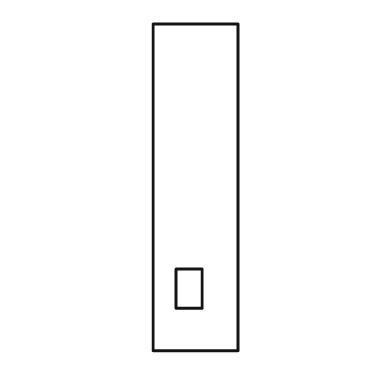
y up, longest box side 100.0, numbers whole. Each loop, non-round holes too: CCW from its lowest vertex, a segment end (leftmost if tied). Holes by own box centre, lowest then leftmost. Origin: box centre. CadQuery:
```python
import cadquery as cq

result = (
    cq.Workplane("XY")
    .moveTo(-13.0, -50.0)
    .lineTo(13.0, -50.0)
    .lineTo(13.0, 50.0)
    .lineTo(-13.0, 50.0)
    .close()
    .moveTo(-6.0, -37.0)
    .lineTo(2.0, -37.0)
    .lineTo(2.0, -25.0)
    .lineTo(-6.0, -25.0)
    .close()
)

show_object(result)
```